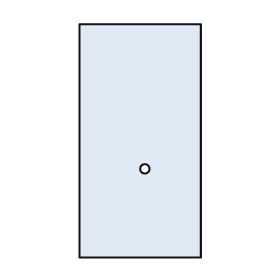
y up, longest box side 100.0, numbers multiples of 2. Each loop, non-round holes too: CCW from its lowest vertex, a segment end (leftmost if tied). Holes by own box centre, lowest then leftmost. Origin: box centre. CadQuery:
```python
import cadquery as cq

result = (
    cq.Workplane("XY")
    .moveTo(-26.0, -50.0)
    .lineTo(26.0, -50.0)
    .lineTo(26.0, 50.0)
    .lineTo(-26.0, 50.0)
    .close()
    .moveTo(2.0, -12.0)
    .circle(2.0)
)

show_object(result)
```